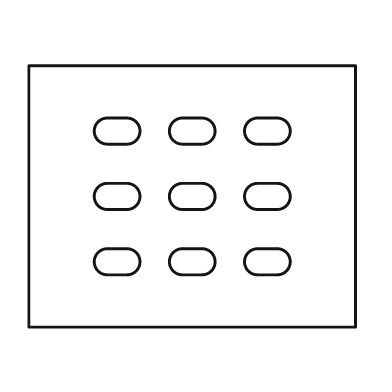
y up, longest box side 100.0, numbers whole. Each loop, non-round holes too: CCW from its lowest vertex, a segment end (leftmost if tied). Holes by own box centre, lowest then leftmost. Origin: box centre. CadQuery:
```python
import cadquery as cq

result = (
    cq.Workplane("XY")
    .moveTo(-50.0, -40.0)
    .lineTo(50.0, -40.0)
    .lineTo(50.0, 40.0)
    .lineTo(-50.0, 40.0)
    .close()
    .moveTo(-26.0, -24.0)
    .lineTo(-20.0, -24.0)
    .threePointArc((-16.0, -20.0), (-20.0, -16.0))
    .lineTo(-26.0, -16.0)
    .threePointArc((-30.0, -20.0), (-26.0, -24.0))
    .close()
    .moveTo(-3.0, -24.0)
    .lineTo(3.0, -24.0)
    .threePointArc((7.0, -20.0), (3.0, -16.0))
    .lineTo(-3.0, -16.0)
    .threePointArc((-7.0, -20.0), (-3.0, -24.0))
    .close()
    .moveTo(20.0, -24.0)
    .lineTo(26.0, -24.0)
    .threePointArc((30.0, -20.0), (26.0, -16.0))
    .lineTo(20.0, -16.0)
    .threePointArc((16.0, -20.0), (20.0, -24.0))
    .close()
    .moveTo(-26.0, -4.0)
    .lineTo(-20.0, -4.0)
    .threePointArc((-16.0, 0.0), (-20.0, 4.0))
    .lineTo(-26.0, 4.0)
    .threePointArc((-30.0, 0.0), (-26.0, -4.0))
    .close()
    .moveTo(-3.0, -4.0)
    .lineTo(3.0, -4.0)
    .threePointArc((7.0, 0.0), (3.0, 4.0))
    .lineTo(-3.0, 4.0)
    .threePointArc((-7.0, 0.0), (-3.0, -4.0))
    .close()
    .moveTo(20.0, -4.0)
    .lineTo(26.0, -4.0)
    .threePointArc((30.0, 0.0), (26.0, 4.0))
    .lineTo(20.0, 4.0)
    .threePointArc((16.0, 0.0), (20.0, -4.0))
    .close()
    .moveTo(-26.0, 16.0)
    .lineTo(-20.0, 16.0)
    .threePointArc((-16.0, 20.0), (-20.0, 24.0))
    .lineTo(-26.0, 24.0)
    .threePointArc((-30.0, 20.0), (-26.0, 16.0))
    .close()
    .moveTo(-3.0, 16.0)
    .lineTo(3.0, 16.0)
    .threePointArc((7.0, 20.0), (3.0, 24.0))
    .lineTo(-3.0, 24.0)
    .threePointArc((-7.0, 20.0), (-3.0, 16.0))
    .close()
    .moveTo(20.0, 16.0)
    .lineTo(26.0, 16.0)
    .threePointArc((30.0, 20.0), (26.0, 24.0))
    .lineTo(20.0, 24.0)
    .threePointArc((16.0, 20.0), (20.0, 16.0))
    .close()
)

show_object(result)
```